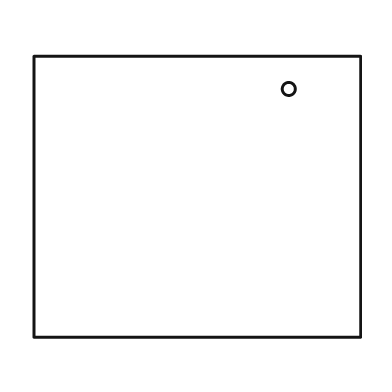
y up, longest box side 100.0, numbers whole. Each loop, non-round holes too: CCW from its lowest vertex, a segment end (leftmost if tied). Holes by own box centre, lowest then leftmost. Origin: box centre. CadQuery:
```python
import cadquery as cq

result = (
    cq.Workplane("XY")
    .moveTo(-50.0, -43.0)
    .lineTo(50.0, -43.0)
    .lineTo(50.0, 43.0)
    .lineTo(-50.0, 43.0)
    .close()
    .moveTo(28.0, 33.0)
    .circle(2.0)
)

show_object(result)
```